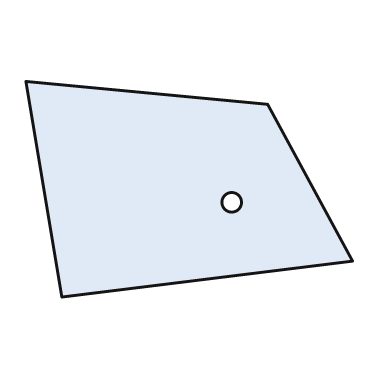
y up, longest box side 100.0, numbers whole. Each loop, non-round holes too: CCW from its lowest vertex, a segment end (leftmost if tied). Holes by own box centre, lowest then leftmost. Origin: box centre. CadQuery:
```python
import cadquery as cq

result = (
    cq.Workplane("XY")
    .moveTo(-39.0, -33.0)
    .lineTo(50.0, -22.0)
    .lineTo(24.0, 26.0)
    .lineTo(-50.0, 33.0)
    .close()
    .moveTo(13.0, -4.0)
    .circle(3.0)
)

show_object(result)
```